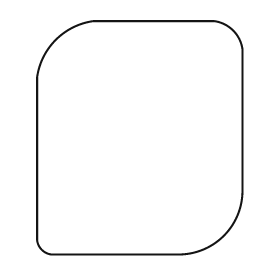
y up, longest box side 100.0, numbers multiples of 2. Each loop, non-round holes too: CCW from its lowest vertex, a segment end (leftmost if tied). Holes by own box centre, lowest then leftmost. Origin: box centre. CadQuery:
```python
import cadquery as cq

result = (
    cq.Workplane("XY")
    .moveTo(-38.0, -50.0)
    .lineTo(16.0, -50.0)
    .threePointArc((36.0, -42.0), (44.0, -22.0))
    .lineTo(44.0, 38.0)
    .threePointArc((40.0, 46.0), (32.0, 50.0))
    .lineTo(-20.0, 50.0)
    .threePointArc((-36.0, 42.0), (-44.0, 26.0))
    .lineTo(-44.0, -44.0)
    .threePointArc((-42.0, -48.0), (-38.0, -50.0))
    .close()
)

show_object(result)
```